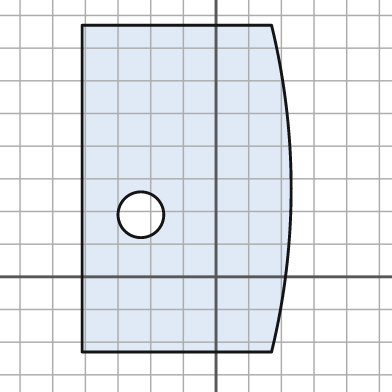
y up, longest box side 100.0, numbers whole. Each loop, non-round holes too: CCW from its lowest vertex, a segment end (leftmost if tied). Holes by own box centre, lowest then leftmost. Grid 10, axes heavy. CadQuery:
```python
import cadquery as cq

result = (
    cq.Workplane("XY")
    .moveTo(-41.0, -23.0)
    .lineTo(17.0, -23.0)
    .threePointArc((23.0, 27.0), (17.0, 77.0))
    .lineTo(-41.0, 77.0)
    .close()
    .moveTo(-23.0, 19.0)
    .circle(7.0)
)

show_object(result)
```